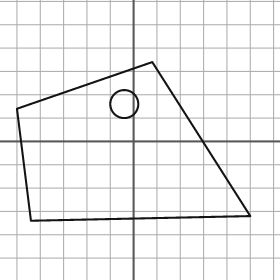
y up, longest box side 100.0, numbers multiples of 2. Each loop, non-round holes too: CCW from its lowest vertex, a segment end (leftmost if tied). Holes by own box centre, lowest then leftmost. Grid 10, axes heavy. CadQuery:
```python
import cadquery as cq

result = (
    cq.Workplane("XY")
    .moveTo(-44.0, -34.0)
    .lineTo(50.0, -32.0)
    .lineTo(8.0, 34.0)
    .lineTo(-50.0, 14.0)
    .close()
    .moveTo(-4.0, 16.0)
    .circle(6.0)
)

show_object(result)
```